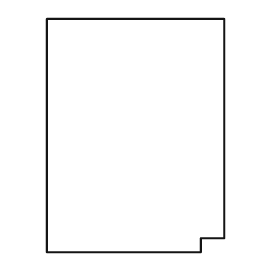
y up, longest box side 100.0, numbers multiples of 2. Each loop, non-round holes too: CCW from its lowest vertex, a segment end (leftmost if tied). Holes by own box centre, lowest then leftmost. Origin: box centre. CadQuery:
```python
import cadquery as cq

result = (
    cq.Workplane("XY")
    .moveTo(-38.0, -50.0)
    .lineTo(28.0, -50.0)
    .lineTo(28.0, -44.0)
    .lineTo(38.0, -44.0)
    .lineTo(38.0, 50.0)
    .lineTo(-38.0, 50.0)
    .close()
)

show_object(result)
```